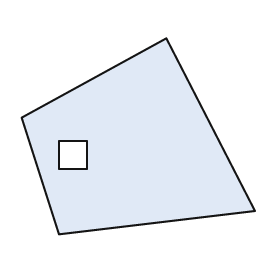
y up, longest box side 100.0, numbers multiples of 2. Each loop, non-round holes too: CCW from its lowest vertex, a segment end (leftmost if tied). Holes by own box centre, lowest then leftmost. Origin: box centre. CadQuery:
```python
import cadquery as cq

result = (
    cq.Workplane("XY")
    .moveTo(-34.0, -42.0)
    .lineTo(50.0, -32.0)
    .lineTo(12.0, 42.0)
    .lineTo(-50.0, 8.0)
    .close()
    .moveTo(-34.0, -14.0)
    .lineTo(-22.0, -14.0)
    .lineTo(-22.0, -2.0)
    .lineTo(-34.0, -2.0)
    .close()
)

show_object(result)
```